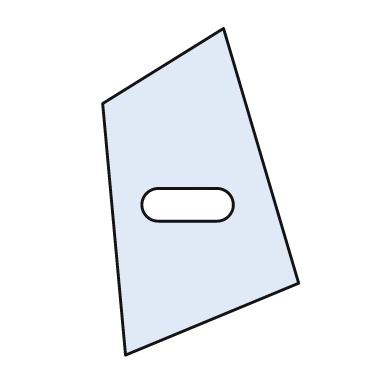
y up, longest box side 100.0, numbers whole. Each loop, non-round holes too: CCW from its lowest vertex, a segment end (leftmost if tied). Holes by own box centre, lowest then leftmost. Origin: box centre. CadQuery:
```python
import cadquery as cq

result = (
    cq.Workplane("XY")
    .moveTo(-23.0, -50.0)
    .lineTo(30.0, -28.0)
    .lineTo(7.0, 50.0)
    .lineTo(-30.0, 27.0)
    .close()
    .moveTo(-13.0, -9.0)
    .lineTo(5.0, -9.0)
    .threePointArc((10.0, -4.0), (5.0, 1.0))
    .lineTo(-13.0, 1.0)
    .threePointArc((-18.0, -4.0), (-13.0, -9.0))
    .close()
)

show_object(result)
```